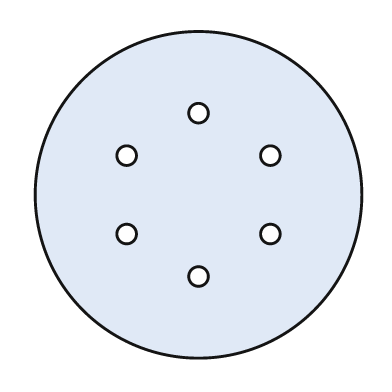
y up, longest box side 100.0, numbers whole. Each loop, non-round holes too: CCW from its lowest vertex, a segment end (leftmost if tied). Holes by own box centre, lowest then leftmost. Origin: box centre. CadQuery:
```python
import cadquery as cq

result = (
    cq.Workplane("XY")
    .moveTo(0.0, 0.0)
    .circle(50.0)
    .moveTo(0.0, -25.0)
    .circle(3.0)
    .moveTo(-22.0, -12.0)
    .circle(3.0)
    .moveTo(22.0, -12.0)
    .circle(3.0)
    .moveTo(-22.0, 12.0)
    .circle(3.0)
    .moveTo(22.0, 12.0)
    .circle(3.0)
    .moveTo(0.0, 25.0)
    .circle(3.0)
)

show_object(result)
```